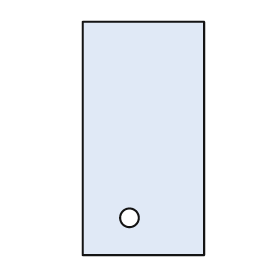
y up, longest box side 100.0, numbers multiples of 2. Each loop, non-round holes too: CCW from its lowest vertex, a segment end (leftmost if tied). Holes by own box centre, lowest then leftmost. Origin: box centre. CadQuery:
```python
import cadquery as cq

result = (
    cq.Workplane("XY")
    .moveTo(-26.0, -50.0)
    .lineTo(26.0, -50.0)
    .lineTo(26.0, 50.0)
    .lineTo(-26.0, 50.0)
    .close()
    .moveTo(-6.0, -34.0)
    .circle(4.0)
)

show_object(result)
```